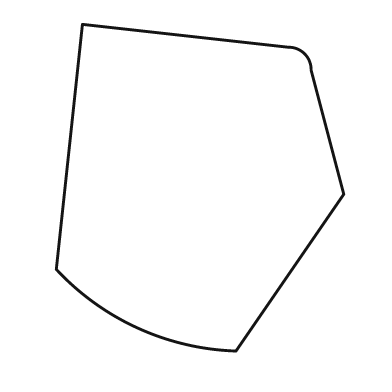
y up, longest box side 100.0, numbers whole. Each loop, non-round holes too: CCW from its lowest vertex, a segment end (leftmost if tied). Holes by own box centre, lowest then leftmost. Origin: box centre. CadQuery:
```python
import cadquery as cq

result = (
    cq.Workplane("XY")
    .moveTo(11.0, -50.0)
    .lineTo(44.0, -2.0)
    .lineTo(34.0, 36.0)
    .threePointArc((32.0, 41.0), (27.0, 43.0))
    .lineTo(-36.0, 50.0)
    .lineTo(-44.0, -25.0)
    .threePointArc((-19.0, -43.0), (11.0, -50.0))
    .close()
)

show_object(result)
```